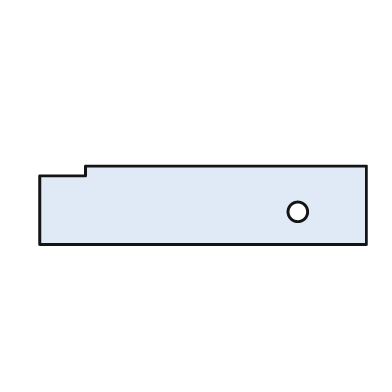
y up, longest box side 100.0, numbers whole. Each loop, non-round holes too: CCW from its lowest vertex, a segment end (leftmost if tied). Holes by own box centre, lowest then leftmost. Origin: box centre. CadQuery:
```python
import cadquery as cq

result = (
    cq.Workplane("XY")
    .moveTo(-50.0, -12.0)
    .lineTo(50.0, -12.0)
    .lineTo(50.0, 12.0)
    .lineTo(-36.0, 12.0)
    .lineTo(-36.0, 9.0)
    .lineTo(-50.0, 9.0)
    .close()
    .moveTo(29.0, -2.0)
    .circle(3.0)
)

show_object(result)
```